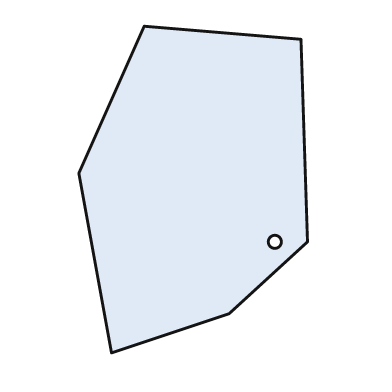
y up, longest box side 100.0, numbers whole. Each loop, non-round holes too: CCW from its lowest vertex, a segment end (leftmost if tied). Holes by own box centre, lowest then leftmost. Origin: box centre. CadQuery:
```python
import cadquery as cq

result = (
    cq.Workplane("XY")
    .moveTo(-25.0, -50.0)
    .lineTo(11.0, -38.0)
    .lineTo(35.0, -16.0)
    .lineTo(33.0, 46.0)
    .lineTo(-15.0, 50.0)
    .lineTo(-35.0, 5.0)
    .close()
    .moveTo(25.0, -16.0)
    .circle(2.0)
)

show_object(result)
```